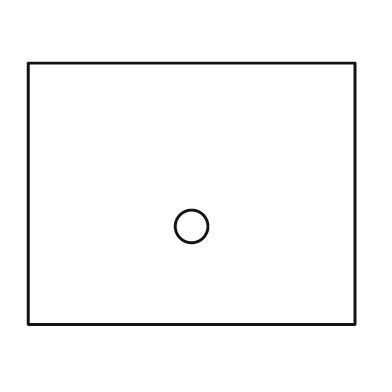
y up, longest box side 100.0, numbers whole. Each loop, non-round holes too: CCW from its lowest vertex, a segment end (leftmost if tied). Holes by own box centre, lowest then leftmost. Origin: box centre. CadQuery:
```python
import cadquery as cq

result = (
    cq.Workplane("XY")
    .moveTo(-50.0, -40.0)
    .lineTo(50.0, -40.0)
    .lineTo(50.0, 40.0)
    .lineTo(-50.0, 40.0)
    .close()
    .moveTo(0.0, -10.0)
    .circle(5.0)
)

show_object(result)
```